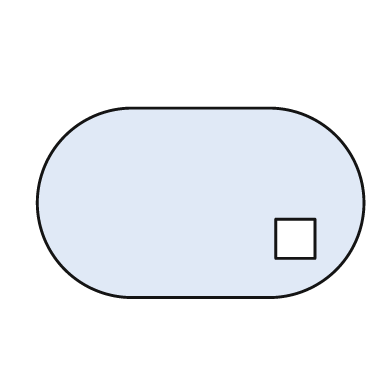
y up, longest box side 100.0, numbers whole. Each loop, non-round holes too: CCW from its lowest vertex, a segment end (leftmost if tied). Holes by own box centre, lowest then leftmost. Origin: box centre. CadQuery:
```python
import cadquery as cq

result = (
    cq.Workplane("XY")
    .moveTo(-21.0, -29.0)
    .lineTo(21.0, -29.0)
    .threePointArc((50.0, 0.0), (21.0, 29.0))
    .lineTo(-21.0, 29.0)
    .threePointArc((-50.0, 0.0), (-21.0, -29.0))
    .close()
    .moveTo(23.0, -17.0)
    .lineTo(35.0, -17.0)
    .lineTo(35.0, -5.0)
    .lineTo(23.0, -5.0)
    .close()
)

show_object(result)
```